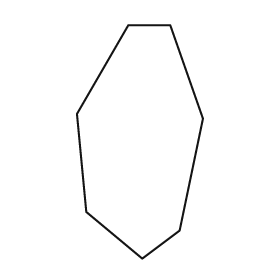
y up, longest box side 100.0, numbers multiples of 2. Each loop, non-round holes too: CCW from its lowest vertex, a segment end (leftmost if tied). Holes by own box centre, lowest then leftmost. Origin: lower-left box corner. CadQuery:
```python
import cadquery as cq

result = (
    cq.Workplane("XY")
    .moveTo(28.0, 0.0)
    .lineTo(44.0, 12.0)
    .lineTo(54.0, 60.0)
    .lineTo(40.0, 100.0)
    .lineTo(22.0, 100.0)
    .lineTo(0.0, 62.0)
    .lineTo(4.0, 20.0)
    .close()
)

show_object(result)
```